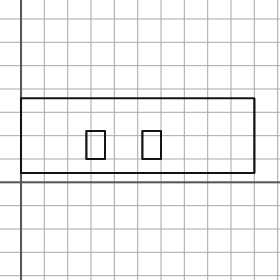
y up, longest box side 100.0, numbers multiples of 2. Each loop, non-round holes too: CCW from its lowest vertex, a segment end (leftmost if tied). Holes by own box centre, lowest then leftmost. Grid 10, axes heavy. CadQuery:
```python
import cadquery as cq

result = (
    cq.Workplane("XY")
    .moveTo(0.0, 4.0)
    .lineTo(100.0, 4.0)
    .lineTo(100.0, 36.0)
    .lineTo(0.0, 36.0)
    .close()
    .moveTo(28.0, 10.0)
    .lineTo(36.0, 10.0)
    .lineTo(36.0, 22.0)
    .lineTo(28.0, 22.0)
    .close()
    .moveTo(52.0, 10.0)
    .lineTo(60.0, 10.0)
    .lineTo(60.0, 22.0)
    .lineTo(52.0, 22.0)
    .close()
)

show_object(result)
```